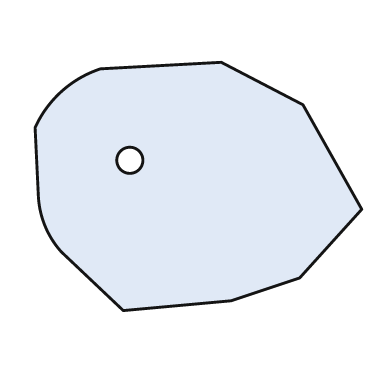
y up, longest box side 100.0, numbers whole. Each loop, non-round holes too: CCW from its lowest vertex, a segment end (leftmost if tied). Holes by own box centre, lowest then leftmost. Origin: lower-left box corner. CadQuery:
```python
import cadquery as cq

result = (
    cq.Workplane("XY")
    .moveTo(27.0, 0.0)
    .lineTo(60.0, 3.0)
    .lineTo(81.0, 10.0)
    .lineTo(100.0, 31.0)
    .lineTo(82.0, 63.0)
    .lineTo(57.0, 76.0)
    .lineTo(20.0, 74.0)
    .threePointArc((8.0, 67.0), (0.0, 56.0))
    .lineTo(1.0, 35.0)
    .threePointArc((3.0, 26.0), (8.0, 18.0))
    .close()
    .moveTo(29.0, 46.0)
    .circle(4.0)
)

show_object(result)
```